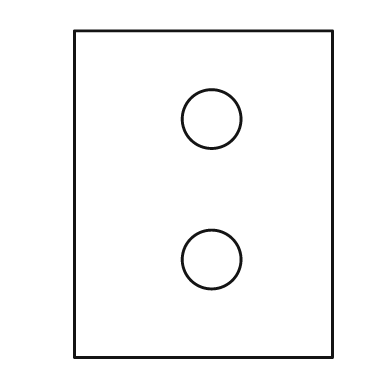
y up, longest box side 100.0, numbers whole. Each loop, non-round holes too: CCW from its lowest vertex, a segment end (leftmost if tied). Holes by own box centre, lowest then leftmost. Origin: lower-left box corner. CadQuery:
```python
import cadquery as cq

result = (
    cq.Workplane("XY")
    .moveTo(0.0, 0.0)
    .lineTo(79.0, 0.0)
    .lineTo(79.0, 100.0)
    .lineTo(0.0, 100.0)
    .close()
    .moveTo(42.0, 30.0)
    .circle(9.0)
    .moveTo(42.0, 73.0)
    .circle(9.0)
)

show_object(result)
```